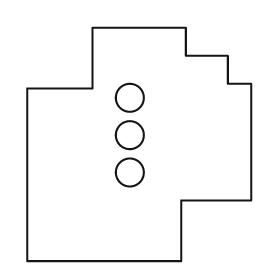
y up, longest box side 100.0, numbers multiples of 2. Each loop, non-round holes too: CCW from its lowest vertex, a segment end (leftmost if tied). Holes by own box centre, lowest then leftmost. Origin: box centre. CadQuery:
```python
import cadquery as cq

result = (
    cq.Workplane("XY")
    .moveTo(-48.0, -50.0)
    .lineTo(18.0, -50.0)
    .lineTo(18.0, -24.0)
    .lineTo(48.0, -24.0)
    .lineTo(48.0, 26.0)
    .lineTo(38.0, 26.0)
    .lineTo(38.0, 38.0)
    .lineTo(20.0, 38.0)
    .lineTo(20.0, 50.0)
    .lineTo(-20.0, 50.0)
    .lineTo(-20.0, 24.0)
    .lineTo(-48.0, 24.0)
    .close()
    .moveTo(-4.0, -12.0)
    .circle(6.0)
    .moveTo(-4.0, 4.0)
    .circle(6.0)
    .moveTo(-4.0, 20.0)
    .circle(6.0)
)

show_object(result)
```